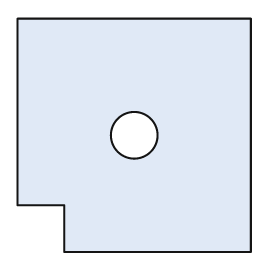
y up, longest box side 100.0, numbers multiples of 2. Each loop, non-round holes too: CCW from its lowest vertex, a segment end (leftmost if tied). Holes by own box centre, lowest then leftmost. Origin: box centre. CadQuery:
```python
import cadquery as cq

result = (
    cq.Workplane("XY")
    .moveTo(-30.0, -50.0)
    .lineTo(50.0, -50.0)
    .lineTo(50.0, 50.0)
    .lineTo(-50.0, 50.0)
    .lineTo(-50.0, -30.0)
    .lineTo(-30.0, -30.0)
    .close()
    .moveTo(0.0, 0.0)
    .circle(10.0)
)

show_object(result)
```